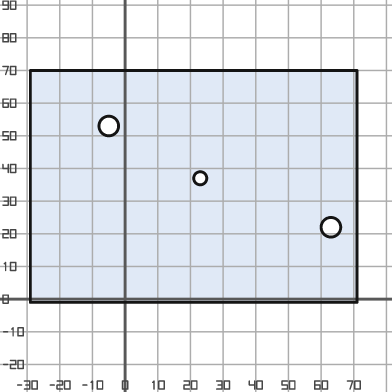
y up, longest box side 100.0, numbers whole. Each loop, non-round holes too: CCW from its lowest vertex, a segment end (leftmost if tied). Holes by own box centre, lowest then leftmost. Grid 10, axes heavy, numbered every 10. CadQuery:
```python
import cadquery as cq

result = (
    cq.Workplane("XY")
    .moveTo(-29.0, -1.0)
    .lineTo(71.0, -1.0)
    .lineTo(71.0, 70.0)
    .lineTo(-29.0, 70.0)
    .close()
    .moveTo(63.0, 22.0)
    .circle(3.0)
    .moveTo(23.0, 37.0)
    .circle(2.0)
    .moveTo(-5.0, 53.0)
    .circle(3.0)
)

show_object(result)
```